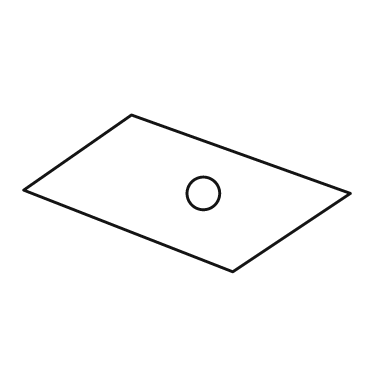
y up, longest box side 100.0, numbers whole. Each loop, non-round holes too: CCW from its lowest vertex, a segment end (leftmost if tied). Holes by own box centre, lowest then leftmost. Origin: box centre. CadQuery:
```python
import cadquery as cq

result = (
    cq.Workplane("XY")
    .moveTo(14.0, -24.0)
    .lineTo(50.0, 0.0)
    .lineTo(-17.0, 24.0)
    .lineTo(-50.0, 1.0)
    .close()
    .moveTo(5.0, 0.0)
    .circle(5.0)
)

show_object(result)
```